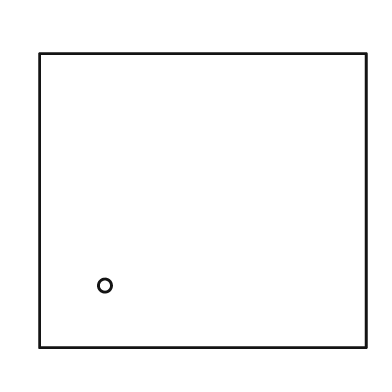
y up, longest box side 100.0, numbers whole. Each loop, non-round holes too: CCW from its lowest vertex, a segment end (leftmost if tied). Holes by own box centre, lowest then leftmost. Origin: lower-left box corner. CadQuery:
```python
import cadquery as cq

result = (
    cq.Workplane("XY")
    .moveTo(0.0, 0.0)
    .lineTo(100.0, 0.0)
    .lineTo(100.0, 90.0)
    .lineTo(0.0, 90.0)
    .close()
    .moveTo(20.0, 19.0)
    .circle(2.0)
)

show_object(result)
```